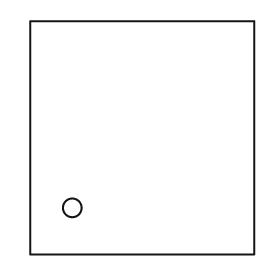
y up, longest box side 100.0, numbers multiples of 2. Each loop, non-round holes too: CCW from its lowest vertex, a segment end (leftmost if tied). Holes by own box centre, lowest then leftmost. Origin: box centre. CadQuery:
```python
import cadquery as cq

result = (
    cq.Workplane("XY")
    .moveTo(-48.0, -50.0)
    .lineTo(48.0, -50.0)
    .lineTo(48.0, 50.0)
    .lineTo(-48.0, 50.0)
    .close()
    .moveTo(-30.0, -30.0)
    .circle(4.0)
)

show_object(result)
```